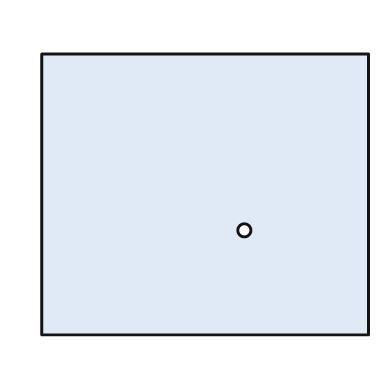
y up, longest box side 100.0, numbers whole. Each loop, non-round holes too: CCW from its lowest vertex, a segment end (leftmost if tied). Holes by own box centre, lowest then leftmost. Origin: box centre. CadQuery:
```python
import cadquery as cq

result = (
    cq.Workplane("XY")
    .moveTo(-50.0, -43.0)
    .lineTo(50.0, -43.0)
    .lineTo(50.0, 43.0)
    .lineTo(-50.0, 43.0)
    .close()
    .moveTo(12.0, -11.0)
    .circle(2.0)
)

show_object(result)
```